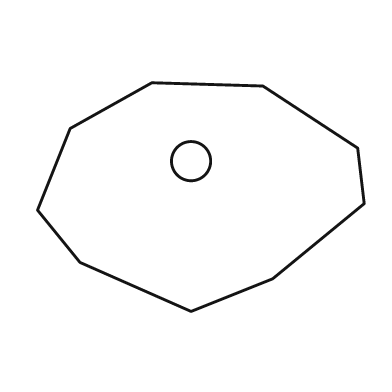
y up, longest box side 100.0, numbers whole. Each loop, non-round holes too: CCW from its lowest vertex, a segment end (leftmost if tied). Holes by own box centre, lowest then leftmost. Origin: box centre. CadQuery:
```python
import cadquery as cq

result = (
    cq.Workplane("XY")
    .moveTo(-3.0, -35.0)
    .lineTo(22.0, -25.0)
    .lineTo(50.0, -2.0)
    .lineTo(48.0, 15.0)
    .lineTo(19.0, 34.0)
    .lineTo(-15.0, 35.0)
    .lineTo(-40.0, 21.0)
    .lineTo(-50.0, -4.0)
    .lineTo(-37.0, -20.0)
    .close()
    .moveTo(-3.0, 11.0)
    .circle(6.0)
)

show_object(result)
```